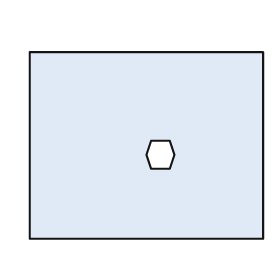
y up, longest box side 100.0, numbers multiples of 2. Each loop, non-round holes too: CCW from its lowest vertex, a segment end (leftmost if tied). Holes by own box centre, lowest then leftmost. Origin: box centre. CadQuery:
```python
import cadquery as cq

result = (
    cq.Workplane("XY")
    .moveTo(-50.0, -40.0)
    .lineTo(50.0, -40.0)
    .lineTo(50.0, 40.0)
    .lineTo(-50.0, 40.0)
    .close()
    .moveTo(2.0, -10.0)
    .lineTo(10.0, -10.0)
    .lineTo(12.0, -4.0)
    .lineTo(10.0, 2.0)
    .lineTo(2.0, 2.0)
    .lineTo(0.0, -4.0)
    .close()
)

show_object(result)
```